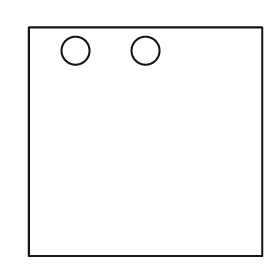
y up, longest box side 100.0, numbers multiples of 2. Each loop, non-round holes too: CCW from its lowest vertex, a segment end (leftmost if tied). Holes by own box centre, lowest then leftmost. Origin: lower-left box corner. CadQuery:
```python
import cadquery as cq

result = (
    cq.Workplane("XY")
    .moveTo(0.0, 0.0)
    .lineTo(100.0, 0.0)
    .lineTo(100.0, 98.0)
    .lineTo(0.0, 98.0)
    .close()
    .moveTo(20.0, 88.0)
    .circle(6.0)
    .moveTo(50.0, 88.0)
    .circle(6.0)
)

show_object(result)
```